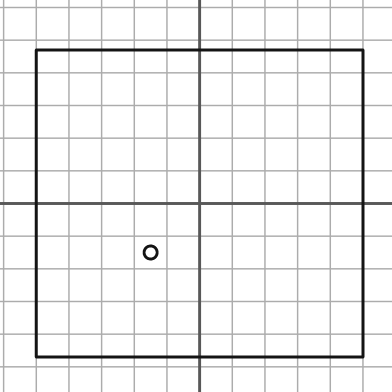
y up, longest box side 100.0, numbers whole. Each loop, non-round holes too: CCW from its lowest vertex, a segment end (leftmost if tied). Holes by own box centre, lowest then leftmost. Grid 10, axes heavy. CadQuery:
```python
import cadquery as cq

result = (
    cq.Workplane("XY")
    .moveTo(-50.0, -47.0)
    .lineTo(50.0, -47.0)
    .lineTo(50.0, 47.0)
    .lineTo(-50.0, 47.0)
    .close()
    .moveTo(-15.0, -15.0)
    .circle(2.0)
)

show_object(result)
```